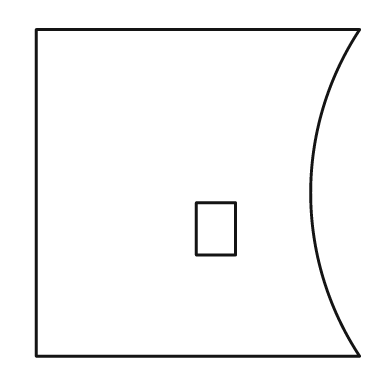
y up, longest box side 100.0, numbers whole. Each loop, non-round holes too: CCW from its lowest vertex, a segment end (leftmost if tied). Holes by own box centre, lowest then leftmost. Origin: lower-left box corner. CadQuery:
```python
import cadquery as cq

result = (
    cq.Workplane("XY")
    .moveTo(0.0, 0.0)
    .lineTo(99.0, 0.0)
    .threePointArc((84.0, 50.0), (99.0, 100.0))
    .lineTo(0.0, 100.0)
    .close()
    .moveTo(49.0, 31.0)
    .lineTo(61.0, 31.0)
    .lineTo(61.0, 47.0)
    .lineTo(49.0, 47.0)
    .close()
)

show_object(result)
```